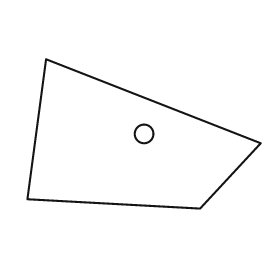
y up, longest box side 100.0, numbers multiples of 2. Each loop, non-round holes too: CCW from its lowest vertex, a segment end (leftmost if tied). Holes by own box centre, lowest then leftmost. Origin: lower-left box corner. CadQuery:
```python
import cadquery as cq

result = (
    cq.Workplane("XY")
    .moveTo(74.0, 0.0)
    .lineTo(100.0, 28.0)
    .lineTo(8.0, 64.0)
    .lineTo(0.0, 4.0)
    .close()
    .moveTo(50.0, 32.0)
    .circle(4.0)
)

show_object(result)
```